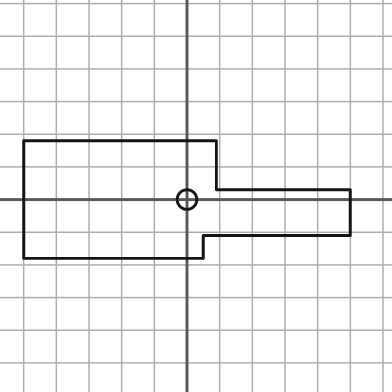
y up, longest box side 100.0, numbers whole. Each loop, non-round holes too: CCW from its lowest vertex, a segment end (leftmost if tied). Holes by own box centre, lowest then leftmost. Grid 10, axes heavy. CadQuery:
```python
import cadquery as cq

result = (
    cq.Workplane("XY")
    .moveTo(-50.0, -18.0)
    .lineTo(5.0, -18.0)
    .lineTo(5.0, -11.0)
    .lineTo(50.0, -11.0)
    .lineTo(50.0, 3.0)
    .lineTo(9.0, 3.0)
    .lineTo(9.0, 18.0)
    .lineTo(-50.0, 18.0)
    .close()
    .moveTo(0.0, 0.0)
    .circle(3.0)
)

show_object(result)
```